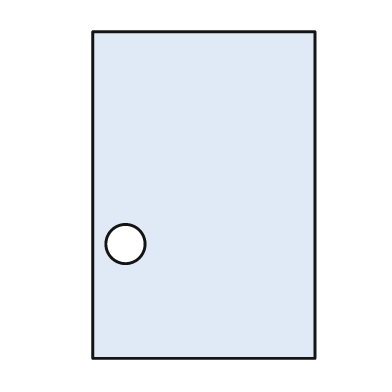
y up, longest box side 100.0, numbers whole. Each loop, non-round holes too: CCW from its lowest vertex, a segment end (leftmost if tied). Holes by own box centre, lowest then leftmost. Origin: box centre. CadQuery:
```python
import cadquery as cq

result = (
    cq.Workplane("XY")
    .moveTo(-34.0, -50.0)
    .lineTo(34.0, -50.0)
    .lineTo(34.0, 50.0)
    .lineTo(-34.0, 50.0)
    .close()
    .moveTo(-24.0, -15.0)
    .circle(6.0)
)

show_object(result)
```